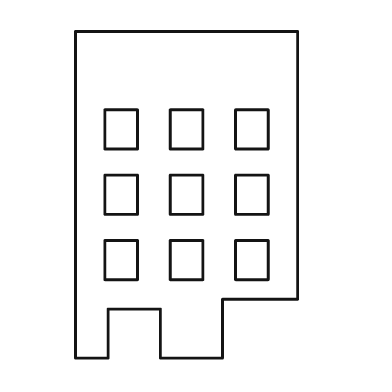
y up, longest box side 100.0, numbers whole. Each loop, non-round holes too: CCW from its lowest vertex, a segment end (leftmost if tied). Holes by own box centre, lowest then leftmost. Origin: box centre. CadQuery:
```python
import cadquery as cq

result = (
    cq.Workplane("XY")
    .moveTo(-34.0, -50.0)
    .lineTo(-24.0, -50.0)
    .lineTo(-24.0, -35.0)
    .lineTo(-8.0, -35.0)
    .lineTo(-8.0, -50.0)
    .lineTo(11.0, -50.0)
    .lineTo(11.0, -32.0)
    .lineTo(34.0, -32.0)
    .lineTo(34.0, 50.0)
    .lineTo(-34.0, 50.0)
    .close()
    .moveTo(-25.0, -26.0)
    .lineTo(-15.0, -26.0)
    .lineTo(-15.0, -14.0)
    .lineTo(-25.0, -14.0)
    .close()
    .moveTo(-5.0, -26.0)
    .lineTo(5.0, -26.0)
    .lineTo(5.0, -14.0)
    .lineTo(-5.0, -14.0)
    .close()
    .moveTo(15.0, -26.0)
    .lineTo(25.0, -26.0)
    .lineTo(25.0, -14.0)
    .lineTo(15.0, -14.0)
    .close()
    .moveTo(-25.0, -6.0)
    .lineTo(-15.0, -6.0)
    .lineTo(-15.0, 6.0)
    .lineTo(-25.0, 6.0)
    .close()
    .moveTo(-5.0, -6.0)
    .lineTo(5.0, -6.0)
    .lineTo(5.0, 6.0)
    .lineTo(-5.0, 6.0)
    .close()
    .moveTo(15.0, -6.0)
    .lineTo(25.0, -6.0)
    .lineTo(25.0, 6.0)
    .lineTo(15.0, 6.0)
    .close()
    .moveTo(-25.0, 14.0)
    .lineTo(-15.0, 14.0)
    .lineTo(-15.0, 26.0)
    .lineTo(-25.0, 26.0)
    .close()
    .moveTo(-5.0, 14.0)
    .lineTo(5.0, 14.0)
    .lineTo(5.0, 26.0)
    .lineTo(-5.0, 26.0)
    .close()
    .moveTo(15.0, 14.0)
    .lineTo(25.0, 14.0)
    .lineTo(25.0, 26.0)
    .lineTo(15.0, 26.0)
    .close()
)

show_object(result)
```